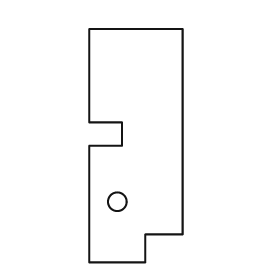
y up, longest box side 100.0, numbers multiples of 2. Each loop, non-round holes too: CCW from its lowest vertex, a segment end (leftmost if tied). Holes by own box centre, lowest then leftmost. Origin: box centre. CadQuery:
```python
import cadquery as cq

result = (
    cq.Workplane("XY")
    .moveTo(-20.0, -50.0)
    .lineTo(4.0, -50.0)
    .lineTo(4.0, -38.0)
    .lineTo(20.0, -38.0)
    .lineTo(20.0, 50.0)
    .lineTo(-20.0, 50.0)
    .lineTo(-20.0, 10.0)
    .lineTo(-6.0, 10.0)
    .lineTo(-6.0, 0.0)
    .lineTo(-20.0, 0.0)
    .close()
    .moveTo(-8.0, -24.0)
    .circle(4.0)
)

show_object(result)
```